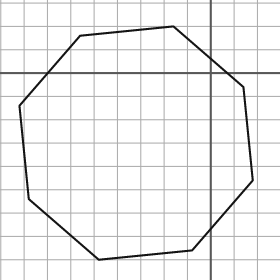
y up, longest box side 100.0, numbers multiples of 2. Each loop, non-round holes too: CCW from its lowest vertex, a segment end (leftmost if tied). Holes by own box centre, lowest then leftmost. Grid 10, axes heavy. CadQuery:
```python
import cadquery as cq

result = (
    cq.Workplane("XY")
    .moveTo(-48.0, -80.0)
    .lineTo(-8.0, -76.0)
    .lineTo(18.0, -46.0)
    .lineTo(14.0, -6.0)
    .lineTo(-16.0, 20.0)
    .lineTo(-56.0, 16.0)
    .lineTo(-82.0, -14.0)
    .lineTo(-78.0, -54.0)
    .close()
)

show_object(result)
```